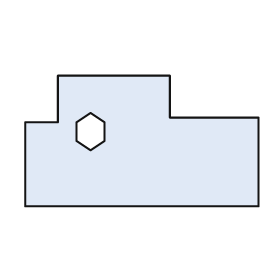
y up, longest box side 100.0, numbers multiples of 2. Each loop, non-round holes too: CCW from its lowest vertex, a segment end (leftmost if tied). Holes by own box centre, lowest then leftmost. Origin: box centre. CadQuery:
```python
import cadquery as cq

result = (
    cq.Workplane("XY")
    .moveTo(-50.0, -28.0)
    .lineTo(50.0, -28.0)
    .lineTo(50.0, 10.0)
    .lineTo(12.0, 10.0)
    .lineTo(12.0, 28.0)
    .lineTo(-36.0, 28.0)
    .lineTo(-36.0, 8.0)
    .lineTo(-50.0, 8.0)
    .close()
    .moveTo(-22.0, -4.0)
    .lineTo(-16.0, 0.0)
    .lineTo(-16.0, 8.0)
    .lineTo(-22.0, 12.0)
    .lineTo(-28.0, 8.0)
    .lineTo(-28.0, 0.0)
    .close()
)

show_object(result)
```